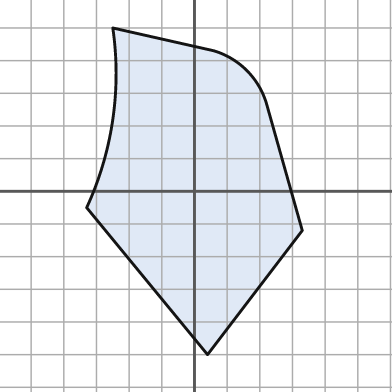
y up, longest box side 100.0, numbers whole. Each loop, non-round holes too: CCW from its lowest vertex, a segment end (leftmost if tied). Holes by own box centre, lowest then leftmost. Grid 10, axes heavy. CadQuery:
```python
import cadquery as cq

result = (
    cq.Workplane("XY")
    .moveTo(4.0, -50.0)
    .lineTo(33.0, -12.0)
    .lineTo(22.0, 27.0)
    .threePointArc((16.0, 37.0), (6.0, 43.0))
    .lineTo(-25.0, 50.0)
    .threePointArc((-25.0, 22.0), (-33.0, -5.0))
    .close()
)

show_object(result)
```